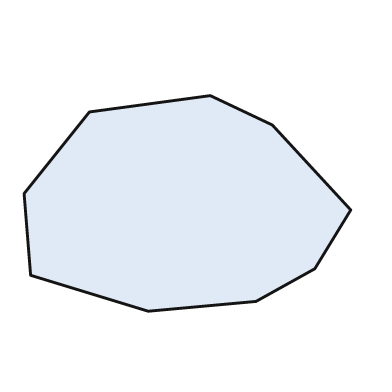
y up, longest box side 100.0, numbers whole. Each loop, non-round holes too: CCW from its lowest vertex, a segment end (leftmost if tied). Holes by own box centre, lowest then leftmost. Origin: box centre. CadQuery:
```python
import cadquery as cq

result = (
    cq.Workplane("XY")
    .moveTo(-12.0, -33.0)
    .lineTo(21.0, -30.0)
    .lineTo(39.0, -20.0)
    .lineTo(50.0, -2.0)
    .lineTo(26.0, 24.0)
    .lineTo(7.0, 33.0)
    .lineTo(-30.0, 28.0)
    .lineTo(-50.0, 3.0)
    .lineTo(-48.0, -22.0)
    .close()
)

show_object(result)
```